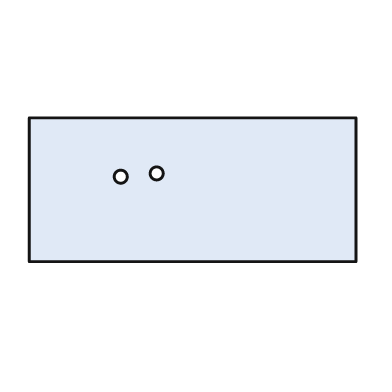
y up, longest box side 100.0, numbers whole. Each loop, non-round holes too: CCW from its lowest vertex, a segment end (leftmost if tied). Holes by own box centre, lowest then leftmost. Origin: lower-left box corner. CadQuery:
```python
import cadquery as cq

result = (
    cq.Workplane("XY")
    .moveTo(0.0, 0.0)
    .lineTo(100.0, 0.0)
    .lineTo(100.0, 44.0)
    .lineTo(0.0, 44.0)
    .close()
    .moveTo(28.0, 26.0)
    .circle(2.0)
    .moveTo(39.0, 27.0)
    .circle(2.0)
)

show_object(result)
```